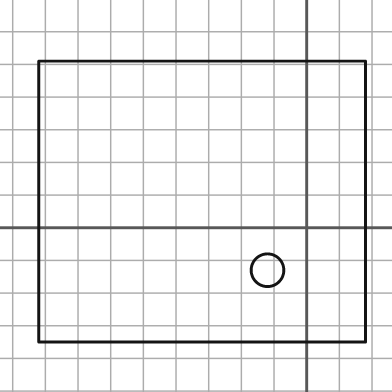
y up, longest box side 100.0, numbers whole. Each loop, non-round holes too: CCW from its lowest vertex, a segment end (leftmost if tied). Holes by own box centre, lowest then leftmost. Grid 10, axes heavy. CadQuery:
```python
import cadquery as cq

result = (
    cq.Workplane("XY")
    .moveTo(-82.0, -35.0)
    .lineTo(18.0, -35.0)
    .lineTo(18.0, 51.0)
    .lineTo(-82.0, 51.0)
    .close()
    .moveTo(-12.0, -13.0)
    .circle(5.0)
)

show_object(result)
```